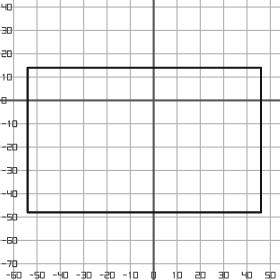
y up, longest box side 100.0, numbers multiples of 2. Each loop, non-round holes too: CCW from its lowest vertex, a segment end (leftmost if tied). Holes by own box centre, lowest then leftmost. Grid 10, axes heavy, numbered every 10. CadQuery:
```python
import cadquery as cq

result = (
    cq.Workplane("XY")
    .moveTo(-54.0, -48.0)
    .lineTo(46.0, -48.0)
    .lineTo(46.0, 14.0)
    .lineTo(-54.0, 14.0)
    .close()
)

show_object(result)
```